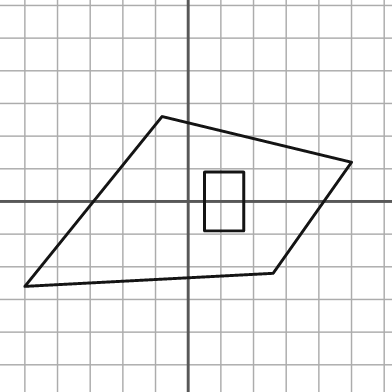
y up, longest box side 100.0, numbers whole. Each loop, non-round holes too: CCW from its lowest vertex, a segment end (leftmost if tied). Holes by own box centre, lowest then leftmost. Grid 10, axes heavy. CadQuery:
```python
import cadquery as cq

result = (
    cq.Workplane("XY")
    .moveTo(-50.0, -26.0)
    .lineTo(26.0, -22.0)
    .lineTo(50.0, 12.0)
    .lineTo(-8.0, 26.0)
    .close()
    .moveTo(5.0, -9.0)
    .lineTo(17.0, -9.0)
    .lineTo(17.0, 9.0)
    .lineTo(5.0, 9.0)
    .close()
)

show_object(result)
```